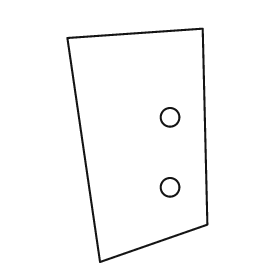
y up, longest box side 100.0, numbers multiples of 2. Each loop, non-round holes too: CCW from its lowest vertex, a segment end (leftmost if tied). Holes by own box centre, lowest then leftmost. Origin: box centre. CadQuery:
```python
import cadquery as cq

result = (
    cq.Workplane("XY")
    .moveTo(-16.0, -50.0)
    .lineTo(30.0, -34.0)
    .lineTo(28.0, 50.0)
    .lineTo(-30.0, 46.0)
    .close()
    .moveTo(14.0, -18.0)
    .circle(4.0)
    .moveTo(14.0, 12.0)
    .circle(4.0)
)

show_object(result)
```